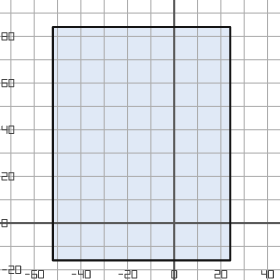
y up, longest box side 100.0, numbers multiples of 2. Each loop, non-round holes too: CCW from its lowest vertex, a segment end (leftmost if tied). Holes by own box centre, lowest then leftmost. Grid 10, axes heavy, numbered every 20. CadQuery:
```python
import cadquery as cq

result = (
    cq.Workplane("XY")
    .moveTo(-52.0, -16.0)
    .lineTo(24.0, -16.0)
    .lineTo(24.0, 84.0)
    .lineTo(-52.0, 84.0)
    .close()
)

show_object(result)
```